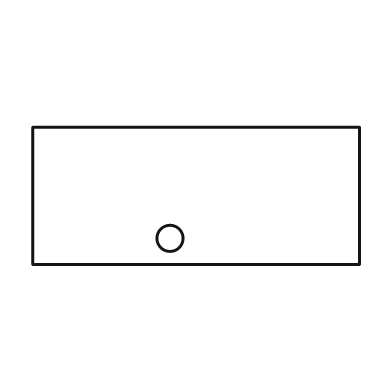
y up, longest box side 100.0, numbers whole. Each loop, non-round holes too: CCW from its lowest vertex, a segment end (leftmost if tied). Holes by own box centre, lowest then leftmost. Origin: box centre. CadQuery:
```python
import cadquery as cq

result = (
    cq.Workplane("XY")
    .moveTo(-50.0, -21.0)
    .lineTo(50.0, -21.0)
    .lineTo(50.0, 21.0)
    .lineTo(-50.0, 21.0)
    .close()
    .moveTo(-8.0, -13.0)
    .circle(4.0)
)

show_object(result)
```